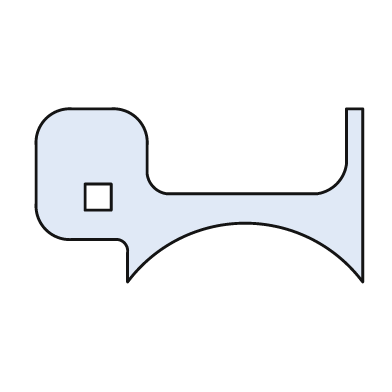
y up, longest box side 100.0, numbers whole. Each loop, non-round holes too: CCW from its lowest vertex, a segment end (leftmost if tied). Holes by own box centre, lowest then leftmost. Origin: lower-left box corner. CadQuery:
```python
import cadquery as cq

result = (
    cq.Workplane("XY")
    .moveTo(28.0, 0.0)
    .threePointArc((64.0, 18.0), (100.0, 0.0))
    .lineTo(100.0, 53.0)
    .lineTo(95.0, 53.0)
    .lineTo(95.0, 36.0)
    .threePointArc((92.0, 30.0), (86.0, 27.0))
    .lineTo(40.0, 27.0)
    .threePointArc((36.0, 29.0), (34.0, 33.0))
    .lineTo(34.0, 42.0)
    .threePointArc((31.0, 50.0), (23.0, 53.0))
    .lineTo(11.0, 53.0)
    .threePointArc((3.0, 50.0), (0.0, 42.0))
    .lineTo(0.0, 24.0)
    .threePointArc((3.0, 16.0), (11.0, 13.0))
    .lineTo(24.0, 13.0)
    .threePointArc((27.0, 12.0), (28.0, 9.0))
    .close()
    .moveTo(15.0, 22.0)
    .lineTo(23.0, 22.0)
    .lineTo(23.0, 30.0)
    .lineTo(15.0, 30.0)
    .close()
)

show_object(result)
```